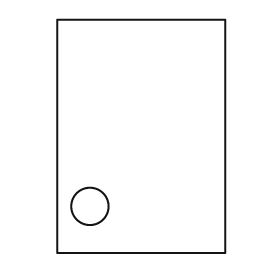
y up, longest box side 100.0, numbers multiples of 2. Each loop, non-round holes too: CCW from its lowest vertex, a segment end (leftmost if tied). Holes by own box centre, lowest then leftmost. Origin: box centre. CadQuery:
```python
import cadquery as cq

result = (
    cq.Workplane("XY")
    .moveTo(-36.0, -50.0)
    .lineTo(36.0, -50.0)
    .lineTo(36.0, 50.0)
    .lineTo(-36.0, 50.0)
    .close()
    .moveTo(-22.0, -30.0)
    .circle(8.0)
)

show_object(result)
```